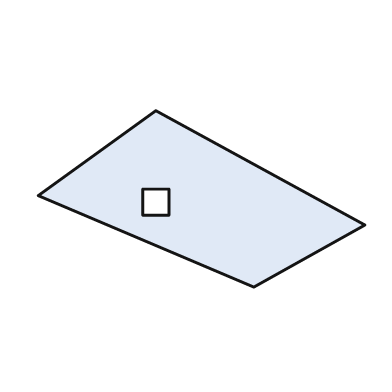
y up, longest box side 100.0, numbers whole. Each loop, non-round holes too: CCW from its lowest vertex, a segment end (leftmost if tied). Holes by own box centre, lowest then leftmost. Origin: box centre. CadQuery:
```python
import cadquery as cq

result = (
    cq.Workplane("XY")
    .moveTo(16.0, -27.0)
    .lineTo(50.0, -8.0)
    .lineTo(-14.0, 27.0)
    .lineTo(-50.0, 1.0)
    .close()
    .moveTo(-18.0, -5.0)
    .lineTo(-10.0, -5.0)
    .lineTo(-10.0, 3.0)
    .lineTo(-18.0, 3.0)
    .close()
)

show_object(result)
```